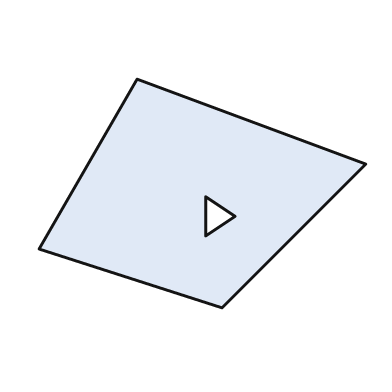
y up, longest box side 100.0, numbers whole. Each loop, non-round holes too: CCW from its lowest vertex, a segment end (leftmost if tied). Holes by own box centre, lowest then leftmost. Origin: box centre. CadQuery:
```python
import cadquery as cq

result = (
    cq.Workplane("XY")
    .moveTo(6.0, -35.0)
    .lineTo(50.0, 9.0)
    .lineTo(-20.0, 35.0)
    .lineTo(-50.0, -17.0)
    .close()
    .moveTo(1.0, -13.0)
    .lineTo(10.0, -7.0)
    .lineTo(1.0, -1.0)
    .close()
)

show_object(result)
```